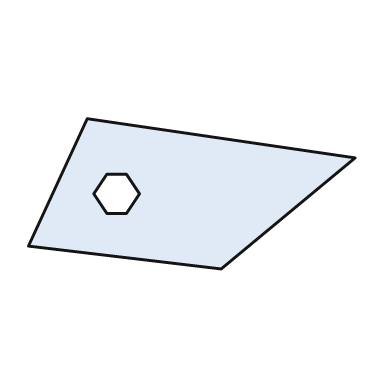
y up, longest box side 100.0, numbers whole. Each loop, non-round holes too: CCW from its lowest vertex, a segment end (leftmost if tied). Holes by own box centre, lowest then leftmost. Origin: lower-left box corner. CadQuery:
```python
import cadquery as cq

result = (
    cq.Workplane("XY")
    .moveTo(59.0, 0.0)
    .lineTo(100.0, 34.0)
    .lineTo(18.0, 46.0)
    .lineTo(0.0, 7.0)
    .close()
    .moveTo(24.0, 17.0)
    .lineTo(30.0, 17.0)
    .lineTo(34.0, 23.0)
    .lineTo(30.0, 29.0)
    .lineTo(24.0, 29.0)
    .lineTo(20.0, 23.0)
    .close()
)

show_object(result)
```